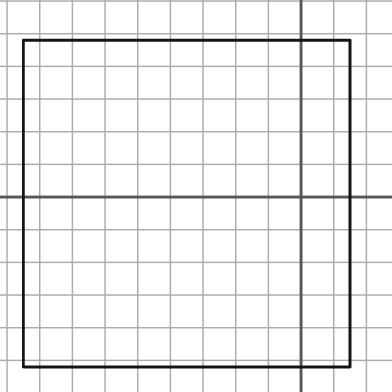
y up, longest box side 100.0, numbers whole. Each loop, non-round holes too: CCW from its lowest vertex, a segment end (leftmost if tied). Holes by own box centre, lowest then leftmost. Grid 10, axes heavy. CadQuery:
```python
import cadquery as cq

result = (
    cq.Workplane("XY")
    .moveTo(-85.0, -52.0)
    .lineTo(15.0, -52.0)
    .lineTo(15.0, 48.0)
    .lineTo(-85.0, 48.0)
    .close()
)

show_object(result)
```